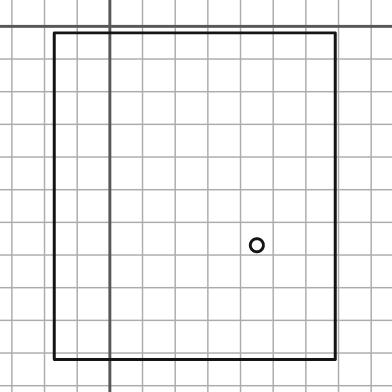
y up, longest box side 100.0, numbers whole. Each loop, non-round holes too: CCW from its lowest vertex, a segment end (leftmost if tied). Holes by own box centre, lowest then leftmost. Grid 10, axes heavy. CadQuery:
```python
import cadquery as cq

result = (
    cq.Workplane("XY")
    .moveTo(-17.0, -102.0)
    .lineTo(69.0, -102.0)
    .lineTo(69.0, -2.0)
    .lineTo(-17.0, -2.0)
    .close()
    .moveTo(45.0, -67.0)
    .circle(2.0)
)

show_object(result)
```